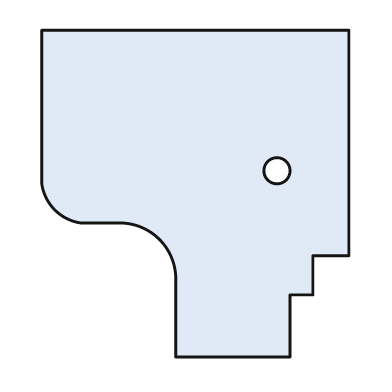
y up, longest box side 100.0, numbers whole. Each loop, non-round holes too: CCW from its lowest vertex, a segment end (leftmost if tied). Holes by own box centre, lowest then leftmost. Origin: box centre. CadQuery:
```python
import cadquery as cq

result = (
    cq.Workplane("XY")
    .moveTo(-6.0, -50.0)
    .lineTo(29.0, -50.0)
    .lineTo(29.0, -31.0)
    .lineTo(36.0, -31.0)
    .lineTo(36.0, -19.0)
    .lineTo(47.0, -19.0)
    .lineTo(47.0, 50.0)
    .lineTo(-47.0, 50.0)
    .lineTo(-47.0, 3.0)
    .threePointArc((-43.0, -5.0), (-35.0, -9.0))
    .lineTo(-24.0, -9.0)
    .threePointArc((-11.0, -14.0), (-6.0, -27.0))
    .close()
    .moveTo(25.0, 7.0)
    .circle(4.0)
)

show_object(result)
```